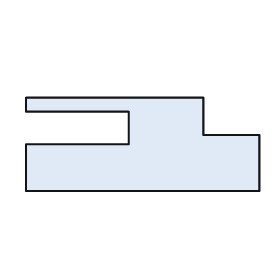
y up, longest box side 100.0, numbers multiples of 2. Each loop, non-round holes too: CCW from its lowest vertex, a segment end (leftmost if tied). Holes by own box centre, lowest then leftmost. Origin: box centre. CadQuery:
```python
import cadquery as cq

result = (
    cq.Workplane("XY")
    .moveTo(-50.0, -20.0)
    .lineTo(50.0, -20.0)
    .lineTo(50.0, 4.0)
    .lineTo(26.0, 4.0)
    .lineTo(26.0, 20.0)
    .lineTo(-50.0, 20.0)
    .lineTo(-50.0, 14.0)
    .lineTo(-6.0, 14.0)
    .lineTo(-6.0, 0.0)
    .lineTo(-50.0, 0.0)
    .close()
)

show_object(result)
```